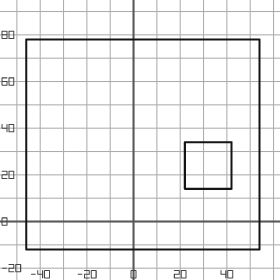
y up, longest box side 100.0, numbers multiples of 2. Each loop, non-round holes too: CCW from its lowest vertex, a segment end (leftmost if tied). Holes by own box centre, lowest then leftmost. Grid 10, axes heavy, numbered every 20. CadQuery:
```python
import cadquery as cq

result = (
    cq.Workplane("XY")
    .moveTo(-46.0, -12.0)
    .lineTo(54.0, -12.0)
    .lineTo(54.0, 78.0)
    .lineTo(-46.0, 78.0)
    .close()
    .moveTo(22.0, 14.0)
    .lineTo(42.0, 14.0)
    .lineTo(42.0, 34.0)
    .lineTo(22.0, 34.0)
    .close()
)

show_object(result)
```